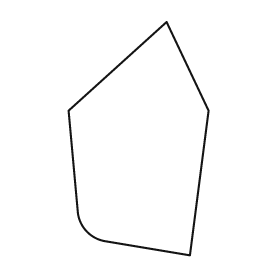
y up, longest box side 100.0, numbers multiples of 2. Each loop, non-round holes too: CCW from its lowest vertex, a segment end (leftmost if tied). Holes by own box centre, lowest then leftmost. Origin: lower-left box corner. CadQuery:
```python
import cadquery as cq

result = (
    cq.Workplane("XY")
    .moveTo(52.0, 0.0)
    .lineTo(60.0, 62.0)
    .lineTo(42.0, 100.0)
    .lineTo(0.0, 62.0)
    .lineTo(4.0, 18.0)
    .threePointArc((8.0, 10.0), (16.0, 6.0))
    .close()
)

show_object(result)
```